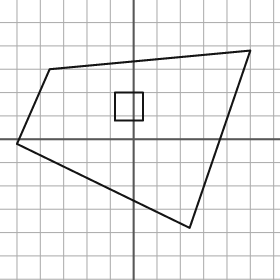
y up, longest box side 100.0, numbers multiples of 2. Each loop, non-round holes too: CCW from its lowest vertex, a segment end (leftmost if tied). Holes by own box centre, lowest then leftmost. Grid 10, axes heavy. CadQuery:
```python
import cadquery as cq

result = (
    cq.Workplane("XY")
    .moveTo(24.0, -38.0)
    .lineTo(50.0, 38.0)
    .lineTo(-36.0, 30.0)
    .lineTo(-50.0, -2.0)
    .close()
    .moveTo(-8.0, 8.0)
    .lineTo(4.0, 8.0)
    .lineTo(4.0, 20.0)
    .lineTo(-8.0, 20.0)
    .close()
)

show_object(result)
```